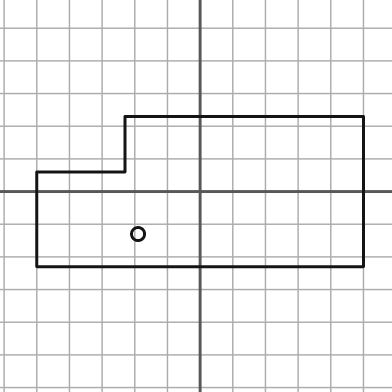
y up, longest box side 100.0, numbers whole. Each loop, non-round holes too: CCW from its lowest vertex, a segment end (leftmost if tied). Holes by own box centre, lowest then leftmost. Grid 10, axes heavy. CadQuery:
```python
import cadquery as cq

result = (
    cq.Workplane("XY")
    .moveTo(-50.0, -23.0)
    .lineTo(50.0, -23.0)
    .lineTo(50.0, 23.0)
    .lineTo(-23.0, 23.0)
    .lineTo(-23.0, 6.0)
    .lineTo(-50.0, 6.0)
    .close()
    .moveTo(-19.0, -13.0)
    .circle(2.0)
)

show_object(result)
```